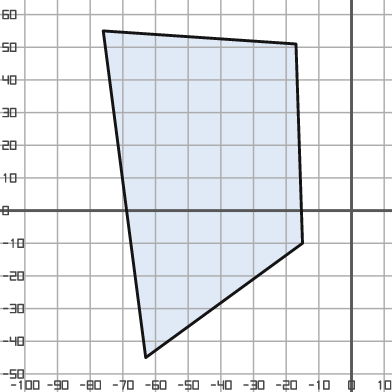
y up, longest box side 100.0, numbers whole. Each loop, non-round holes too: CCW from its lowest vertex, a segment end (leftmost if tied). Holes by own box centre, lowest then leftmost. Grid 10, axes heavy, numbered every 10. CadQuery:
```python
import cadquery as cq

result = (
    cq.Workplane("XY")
    .moveTo(-63.0, -45.0)
    .lineTo(-15.0, -10.0)
    .lineTo(-17.0, 51.0)
    .lineTo(-76.0, 55.0)
    .close()
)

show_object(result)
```